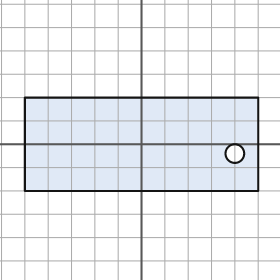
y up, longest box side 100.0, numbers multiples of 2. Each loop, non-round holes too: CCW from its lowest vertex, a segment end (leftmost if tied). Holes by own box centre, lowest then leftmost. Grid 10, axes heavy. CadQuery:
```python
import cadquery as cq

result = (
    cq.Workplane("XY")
    .moveTo(-50.0, -20.0)
    .lineTo(50.0, -20.0)
    .lineTo(50.0, 20.0)
    .lineTo(-50.0, 20.0)
    .close()
    .moveTo(40.0, -4.0)
    .circle(4.0)
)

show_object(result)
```